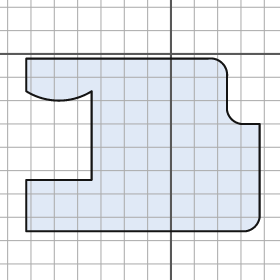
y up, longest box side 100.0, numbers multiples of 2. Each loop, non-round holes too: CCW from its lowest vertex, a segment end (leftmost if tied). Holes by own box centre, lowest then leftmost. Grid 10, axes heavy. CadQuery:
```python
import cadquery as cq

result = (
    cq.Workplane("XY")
    .moveTo(-62.0, -76.0)
    .lineTo(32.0, -76.0)
    .threePointArc((36.0, -74.0), (38.0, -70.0))
    .lineTo(38.0, -30.0)
    .lineTo(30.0, -30.0)
    .threePointArc((26.0, -28.0), (24.0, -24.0))
    .lineTo(24.0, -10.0)
    .threePointArc((22.0, -4.0), (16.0, -2.0))
    .lineTo(-62.0, -2.0)
    .lineTo(-62.0, -16.0)
    .threePointArc((-48.0, -20.0), (-34.0, -16.0))
    .lineTo(-34.0, -54.0)
    .lineTo(-62.0, -54.0)
    .close()
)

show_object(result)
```